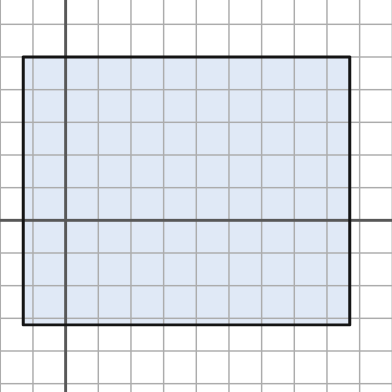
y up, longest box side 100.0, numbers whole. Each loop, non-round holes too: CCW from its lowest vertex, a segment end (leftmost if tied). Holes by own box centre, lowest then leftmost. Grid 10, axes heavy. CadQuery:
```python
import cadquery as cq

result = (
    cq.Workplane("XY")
    .moveTo(-13.0, -32.0)
    .lineTo(87.0, -32.0)
    .lineTo(87.0, 50.0)
    .lineTo(-13.0, 50.0)
    .close()
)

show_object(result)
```